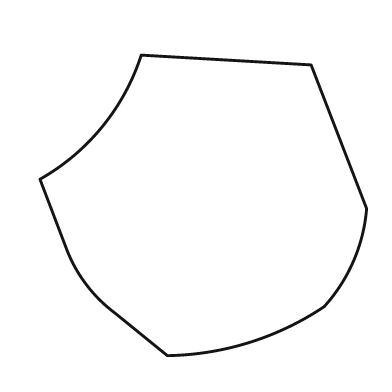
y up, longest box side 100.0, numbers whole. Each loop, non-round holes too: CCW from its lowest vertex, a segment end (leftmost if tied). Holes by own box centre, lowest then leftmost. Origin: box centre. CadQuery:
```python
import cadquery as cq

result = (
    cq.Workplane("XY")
    .moveTo(-11.0, -46.0)
    .threePointArc((14.0, -42.0), (37.0, -31.0))
    .threePointArc((46.0, -17.0), (50.0, -1.0))
    .lineTo(33.0, 43.0)
    .lineTo(-19.0, 46.0)
    .threePointArc((-31.0, 24.0), (-50.0, 8.0))
    .lineTo(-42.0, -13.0)
    .threePointArc((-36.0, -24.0), (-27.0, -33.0))
    .close()
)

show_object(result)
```